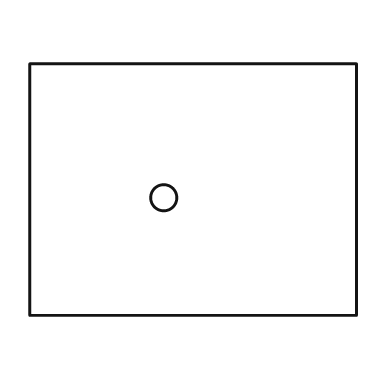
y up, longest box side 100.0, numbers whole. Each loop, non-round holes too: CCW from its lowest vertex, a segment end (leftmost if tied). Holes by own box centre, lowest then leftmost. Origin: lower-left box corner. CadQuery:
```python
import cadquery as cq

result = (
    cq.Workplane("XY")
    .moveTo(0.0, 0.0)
    .lineTo(100.0, 0.0)
    .lineTo(100.0, 77.0)
    .lineTo(0.0, 77.0)
    .close()
    .moveTo(41.0, 36.0)
    .circle(4.0)
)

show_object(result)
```